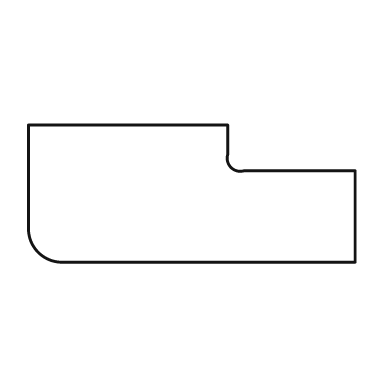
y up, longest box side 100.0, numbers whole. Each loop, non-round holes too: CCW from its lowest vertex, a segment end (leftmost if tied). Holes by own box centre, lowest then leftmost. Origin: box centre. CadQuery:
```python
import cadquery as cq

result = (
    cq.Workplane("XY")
    .moveTo(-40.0, -21.0)
    .lineTo(50.0, -21.0)
    .lineTo(50.0, 7.0)
    .lineTo(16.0, 7.0)
    .threePointArc((12.0, 8.0), (11.0, 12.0))
    .lineTo(11.0, 21.0)
    .lineTo(-50.0, 21.0)
    .lineTo(-50.0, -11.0)
    .threePointArc((-47.0, -18.0), (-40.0, -21.0))
    .close()
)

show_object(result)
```